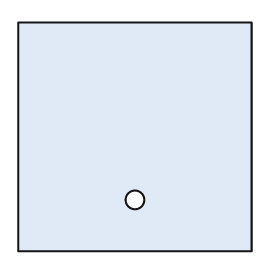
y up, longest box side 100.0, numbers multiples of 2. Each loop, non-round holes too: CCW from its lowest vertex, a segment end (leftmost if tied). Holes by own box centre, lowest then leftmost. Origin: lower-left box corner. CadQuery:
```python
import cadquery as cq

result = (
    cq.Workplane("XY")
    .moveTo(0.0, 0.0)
    .lineTo(100.0, 0.0)
    .lineTo(100.0, 98.0)
    .lineTo(0.0, 98.0)
    .close()
    .moveTo(50.0, 22.0)
    .circle(4.0)
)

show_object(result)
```